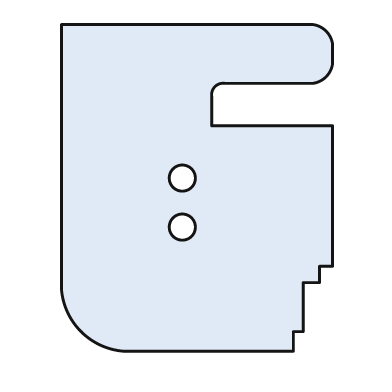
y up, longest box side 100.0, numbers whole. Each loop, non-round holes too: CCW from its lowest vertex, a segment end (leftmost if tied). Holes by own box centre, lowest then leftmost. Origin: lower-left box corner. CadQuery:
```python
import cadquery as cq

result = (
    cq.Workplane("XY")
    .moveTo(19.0, 0.0)
    .lineTo(71.0, 0.0)
    .lineTo(71.0, 6.0)
    .lineTo(74.0, 6.0)
    .lineTo(74.0, 21.0)
    .lineTo(79.0, 21.0)
    .lineTo(79.0, 26.0)
    .lineTo(83.0, 26.0)
    .lineTo(83.0, 69.0)
    .lineTo(46.0, 69.0)
    .lineTo(46.0, 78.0)
    .threePointArc((47.0, 81.0), (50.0, 82.0))
    .lineTo(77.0, 82.0)
    .threePointArc((81.0, 84.0), (83.0, 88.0))
    .lineTo(83.0, 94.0)
    .threePointArc((81.0, 98.0), (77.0, 100.0))
    .lineTo(0.0, 100.0)
    .lineTo(0.0, 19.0)
    .threePointArc((6.0, 6.0), (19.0, 0.0))
    .close()
    .moveTo(37.0, 38.0)
    .circle(4.0)
    .moveTo(37.0, 53.0)
    .circle(4.0)
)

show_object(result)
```